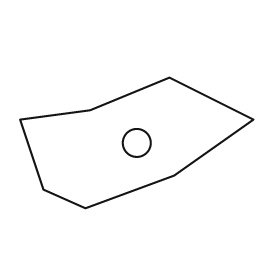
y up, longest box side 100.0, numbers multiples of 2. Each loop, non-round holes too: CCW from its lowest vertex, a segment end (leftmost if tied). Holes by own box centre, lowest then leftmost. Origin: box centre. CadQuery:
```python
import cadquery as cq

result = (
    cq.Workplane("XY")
    .moveTo(-22.0, -28.0)
    .lineTo(16.0, -14.0)
    .lineTo(50.0, 10.0)
    .lineTo(14.0, 28.0)
    .lineTo(-20.0, 14.0)
    .lineTo(-50.0, 10.0)
    .lineTo(-40.0, -20.0)
    .close()
    .moveTo(0.0, 0.0)
    .circle(6.0)
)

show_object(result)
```